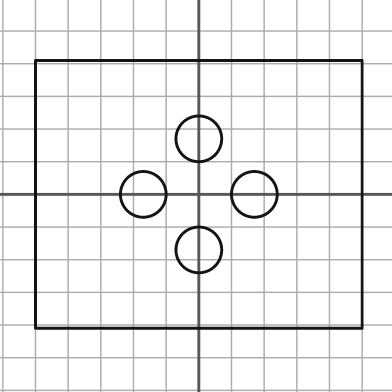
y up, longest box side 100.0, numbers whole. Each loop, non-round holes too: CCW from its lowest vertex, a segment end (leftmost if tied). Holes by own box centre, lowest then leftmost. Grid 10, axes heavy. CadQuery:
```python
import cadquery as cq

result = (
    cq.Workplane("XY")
    .moveTo(-50.0, -41.0)
    .lineTo(50.0, -41.0)
    .lineTo(50.0, 41.0)
    .lineTo(-50.0, 41.0)
    .close()
    .moveTo(0.0, -17.0)
    .circle(7.0)
    .moveTo(-17.0, 0.0)
    .circle(7.0)
    .moveTo(17.0, 0.0)
    .circle(7.0)
    .moveTo(0.0, 17.0)
    .circle(7.0)
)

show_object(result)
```